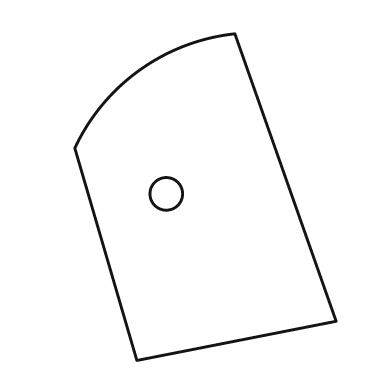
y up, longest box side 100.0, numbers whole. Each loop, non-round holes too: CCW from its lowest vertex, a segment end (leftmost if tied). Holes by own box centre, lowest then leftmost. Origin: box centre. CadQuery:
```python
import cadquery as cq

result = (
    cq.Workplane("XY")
    .moveTo(-21.0, -50.0)
    .lineTo(40.0, -38.0)
    .lineTo(9.0, 50.0)
    .threePointArc((-20.0, 39.0), (-40.0, 15.0))
    .close()
    .moveTo(-12.0, 1.0)
    .circle(5.0)
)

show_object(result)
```